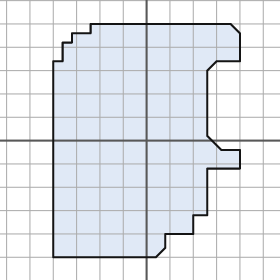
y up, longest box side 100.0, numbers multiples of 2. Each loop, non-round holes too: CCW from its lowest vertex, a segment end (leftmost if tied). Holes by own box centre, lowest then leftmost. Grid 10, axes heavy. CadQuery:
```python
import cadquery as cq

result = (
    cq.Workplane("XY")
    .moveTo(-40.0, -50.0)
    .lineTo(4.0, -50.0)
    .lineTo(8.0, -46.0)
    .lineTo(8.0, -40.0)
    .lineTo(20.0, -40.0)
    .lineTo(20.0, -32.0)
    .lineTo(26.0, -32.0)
    .lineTo(26.0, -12.0)
    .lineTo(40.0, -12.0)
    .lineTo(40.0, -4.0)
    .lineTo(32.0, -4.0)
    .lineTo(26.0, 2.0)
    .lineTo(26.0, 30.0)
    .lineTo(30.0, 34.0)
    .lineTo(40.0, 34.0)
    .lineTo(40.0, 46.0)
    .lineTo(36.0, 50.0)
    .lineTo(-24.0, 50.0)
    .lineTo(-24.0, 46.0)
    .lineTo(-32.0, 46.0)
    .lineTo(-32.0, 42.0)
    .lineTo(-36.0, 42.0)
    .lineTo(-36.0, 34.0)
    .lineTo(-40.0, 34.0)
    .close()
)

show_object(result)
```